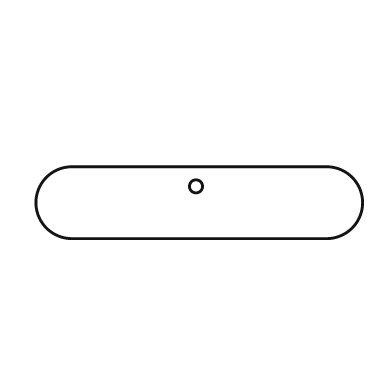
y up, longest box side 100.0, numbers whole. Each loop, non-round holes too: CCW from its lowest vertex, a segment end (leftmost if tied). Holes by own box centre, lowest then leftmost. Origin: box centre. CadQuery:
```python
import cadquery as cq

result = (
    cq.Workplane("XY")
    .moveTo(-39.0, -11.0)
    .lineTo(39.0, -11.0)
    .threePointArc((50.0, 0.0), (39.0, 11.0))
    .lineTo(-39.0, 11.0)
    .threePointArc((-50.0, 0.0), (-39.0, -11.0))
    .close()
    .moveTo(-1.0, 5.0)
    .circle(2.0)
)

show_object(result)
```